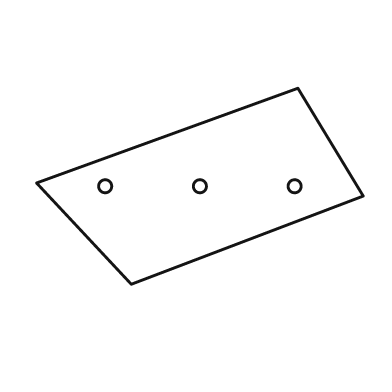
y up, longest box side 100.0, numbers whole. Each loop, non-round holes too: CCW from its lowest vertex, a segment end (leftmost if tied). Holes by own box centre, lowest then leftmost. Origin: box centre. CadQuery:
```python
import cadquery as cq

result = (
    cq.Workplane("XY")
    .moveTo(-21.0, -30.0)
    .lineTo(50.0, -3.0)
    .lineTo(30.0, 30.0)
    .lineTo(-50.0, 1.0)
    .close()
    .moveTo(-29.0, 0.0)
    .circle(2.0)
    .moveTo(0.0, 0.0)
    .circle(2.0)
    .moveTo(29.0, 0.0)
    .circle(2.0)
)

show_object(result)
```